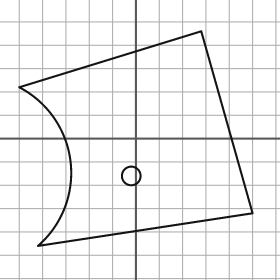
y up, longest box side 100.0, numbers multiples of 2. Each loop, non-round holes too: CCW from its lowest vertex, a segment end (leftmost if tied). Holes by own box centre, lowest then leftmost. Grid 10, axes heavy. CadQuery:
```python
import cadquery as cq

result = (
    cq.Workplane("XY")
    .moveTo(-42.0, -46.0)
    .lineTo(50.0, -32.0)
    .lineTo(28.0, 46.0)
    .lineTo(-50.0, 22.0)
    .threePointArc((-28.0, -10.0), (-42.0, -46.0))
    .close()
    .moveTo(-2.0, -16.0)
    .circle(4.0)
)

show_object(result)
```